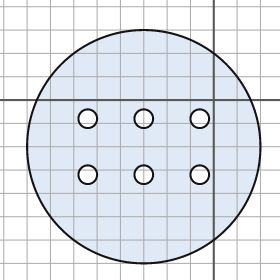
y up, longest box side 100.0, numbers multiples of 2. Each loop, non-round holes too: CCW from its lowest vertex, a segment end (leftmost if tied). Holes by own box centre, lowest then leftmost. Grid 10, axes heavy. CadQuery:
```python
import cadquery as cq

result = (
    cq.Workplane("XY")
    .moveTo(-30.0, -20.0)
    .circle(50.0)
    .moveTo(-54.0, -32.0)
    .circle(4.0)
    .moveTo(-30.0, -32.0)
    .circle(4.0)
    .moveTo(-6.0, -32.0)
    .circle(4.0)
    .moveTo(-54.0, -8.0)
    .circle(4.0)
    .moveTo(-30.0, -8.0)
    .circle(4.0)
    .moveTo(-6.0, -8.0)
    .circle(4.0)
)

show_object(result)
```